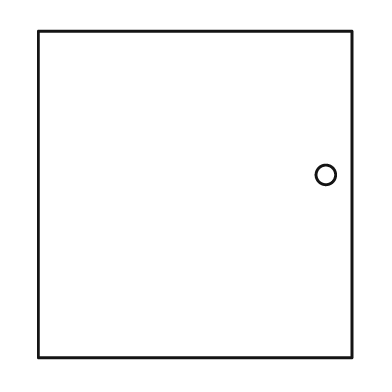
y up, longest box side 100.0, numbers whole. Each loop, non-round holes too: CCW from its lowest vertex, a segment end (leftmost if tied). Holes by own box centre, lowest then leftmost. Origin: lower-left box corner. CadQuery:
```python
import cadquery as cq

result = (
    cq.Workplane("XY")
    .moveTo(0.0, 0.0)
    .lineTo(96.0, 0.0)
    .lineTo(96.0, 100.0)
    .lineTo(0.0, 100.0)
    .close()
    .moveTo(88.0, 56.0)
    .circle(3.0)
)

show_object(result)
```